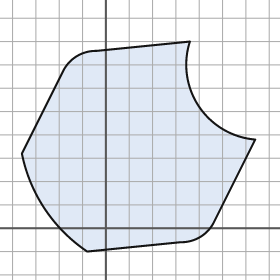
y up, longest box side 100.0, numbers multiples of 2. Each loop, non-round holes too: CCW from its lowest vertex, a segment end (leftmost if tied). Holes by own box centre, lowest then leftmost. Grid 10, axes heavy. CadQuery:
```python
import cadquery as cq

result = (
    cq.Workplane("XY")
    .moveTo(-8.0, -10.0)
    .lineTo(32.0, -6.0)
    .threePointArc((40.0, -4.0), (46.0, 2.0))
    .lineTo(64.0, 38.0)
    .threePointArc((40.0, 52.0), (36.0, 80.0))
    .lineTo(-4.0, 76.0)
    .threePointArc((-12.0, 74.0), (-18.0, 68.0))
    .lineTo(-36.0, 32.0)
    .threePointArc((-26.0, 8.0), (-8.0, -10.0))
    .close()
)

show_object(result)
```